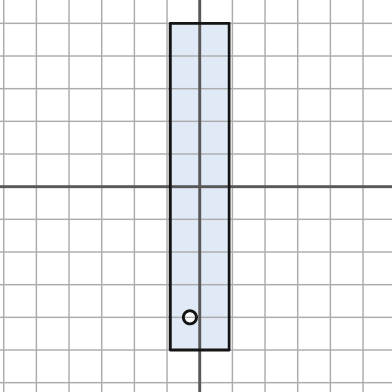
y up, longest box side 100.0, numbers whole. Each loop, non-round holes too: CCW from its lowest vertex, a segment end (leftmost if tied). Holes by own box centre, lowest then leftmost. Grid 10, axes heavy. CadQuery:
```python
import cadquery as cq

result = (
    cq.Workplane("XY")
    .moveTo(-9.0, -50.0)
    .lineTo(9.0, -50.0)
    .lineTo(9.0, 50.0)
    .lineTo(-9.0, 50.0)
    .close()
    .moveTo(-3.0, -40.0)
    .circle(2.0)
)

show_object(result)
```